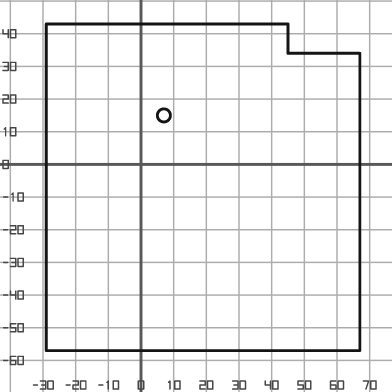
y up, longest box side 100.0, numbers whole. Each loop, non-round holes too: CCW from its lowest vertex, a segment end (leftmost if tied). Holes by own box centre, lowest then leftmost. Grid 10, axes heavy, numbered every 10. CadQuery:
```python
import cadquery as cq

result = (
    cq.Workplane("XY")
    .moveTo(-29.0, -57.0)
    .lineTo(67.0, -57.0)
    .lineTo(67.0, 34.0)
    .lineTo(45.0, 34.0)
    .lineTo(45.0, 43.0)
    .lineTo(-29.0, 43.0)
    .close()
    .moveTo(7.0, 15.0)
    .circle(2.0)
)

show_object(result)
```